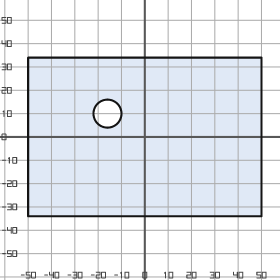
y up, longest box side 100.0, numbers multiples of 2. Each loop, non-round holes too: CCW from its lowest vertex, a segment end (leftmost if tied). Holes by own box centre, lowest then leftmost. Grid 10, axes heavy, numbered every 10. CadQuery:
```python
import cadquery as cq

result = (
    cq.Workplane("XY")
    .moveTo(-50.0, -34.0)
    .lineTo(50.0, -34.0)
    .lineTo(50.0, 34.0)
    .lineTo(-50.0, 34.0)
    .close()
    .moveTo(-16.0, 10.0)
    .circle(6.0)
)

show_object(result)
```